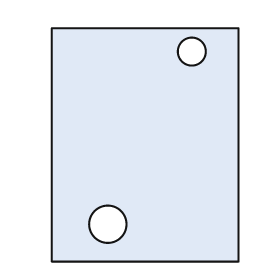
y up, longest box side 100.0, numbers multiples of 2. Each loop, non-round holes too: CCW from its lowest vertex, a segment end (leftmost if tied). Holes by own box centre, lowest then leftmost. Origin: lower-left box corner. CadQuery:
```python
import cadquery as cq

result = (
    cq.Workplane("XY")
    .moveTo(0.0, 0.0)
    .lineTo(80.0, 0.0)
    .lineTo(80.0, 100.0)
    .lineTo(0.0, 100.0)
    .close()
    .moveTo(24.0, 16.0)
    .circle(8.0)
    .moveTo(60.0, 90.0)
    .circle(6.0)
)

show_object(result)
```